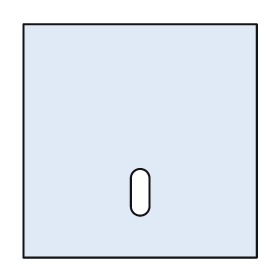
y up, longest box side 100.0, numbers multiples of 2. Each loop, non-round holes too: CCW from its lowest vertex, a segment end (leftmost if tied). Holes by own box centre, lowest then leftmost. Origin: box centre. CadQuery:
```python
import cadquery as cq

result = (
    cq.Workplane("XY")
    .moveTo(-50.0, -50.0)
    .lineTo(50.0, -50.0)
    .lineTo(50.0, 50.0)
    .lineTo(-50.0, 50.0)
    .close()
    .moveTo(-4.0, -28.0)
    .threePointArc((0.0, -32.0), (4.0, -28.0))
    .lineTo(4.0, -16.0)
    .threePointArc((0.0, -12.0), (-4.0, -16.0))
    .close()
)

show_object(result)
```